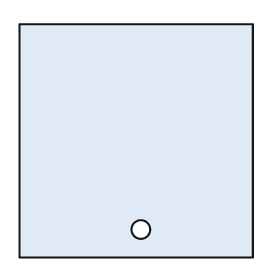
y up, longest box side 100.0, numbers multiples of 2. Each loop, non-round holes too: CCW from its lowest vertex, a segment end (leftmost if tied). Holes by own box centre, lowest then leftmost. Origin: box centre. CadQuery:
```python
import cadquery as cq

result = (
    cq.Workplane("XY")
    .moveTo(-50.0, -50.0)
    .lineTo(50.0, -50.0)
    .lineTo(50.0, 50.0)
    .lineTo(-50.0, 50.0)
    .close()
    .moveTo(2.0, -38.0)
    .circle(4.0)
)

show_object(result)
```